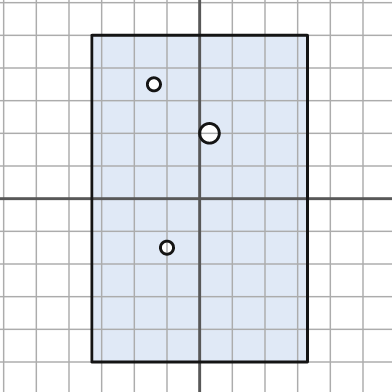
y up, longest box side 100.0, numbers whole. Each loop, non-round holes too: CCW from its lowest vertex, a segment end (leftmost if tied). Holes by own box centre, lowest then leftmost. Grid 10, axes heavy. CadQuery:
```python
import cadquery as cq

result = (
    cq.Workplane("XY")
    .moveTo(-33.0, -50.0)
    .lineTo(33.0, -50.0)
    .lineTo(33.0, 50.0)
    .lineTo(-33.0, 50.0)
    .close()
    .moveTo(-10.0, -15.0)
    .circle(2.0)
    .moveTo(3.0, 20.0)
    .circle(3.0)
    .moveTo(-14.0, 35.0)
    .circle(2.0)
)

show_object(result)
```